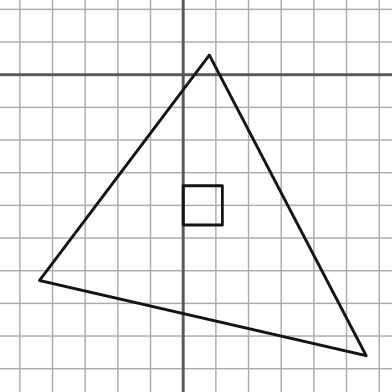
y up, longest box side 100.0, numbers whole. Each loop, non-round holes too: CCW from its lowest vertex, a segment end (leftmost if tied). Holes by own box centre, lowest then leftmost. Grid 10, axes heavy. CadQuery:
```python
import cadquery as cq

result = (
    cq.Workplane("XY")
    .moveTo(56.0, -86.0)
    .lineTo(8.0, 6.0)
    .lineTo(-44.0, -63.0)
    .close()
    .moveTo(0.0, -46.0)
    .lineTo(12.0, -46.0)
    .lineTo(12.0, -34.0)
    .lineTo(0.0, -34.0)
    .close()
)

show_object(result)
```